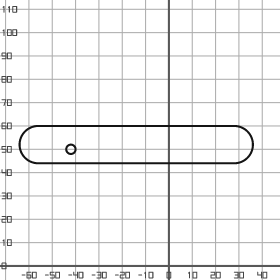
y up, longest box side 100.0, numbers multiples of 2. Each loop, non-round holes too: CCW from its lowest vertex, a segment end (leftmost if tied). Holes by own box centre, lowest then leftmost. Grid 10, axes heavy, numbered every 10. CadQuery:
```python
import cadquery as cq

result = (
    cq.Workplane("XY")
    .moveTo(-56.0, 44.0)
    .lineTo(28.0, 44.0)
    .threePointArc((36.0, 52.0), (28.0, 60.0))
    .lineTo(-56.0, 60.0)
    .threePointArc((-64.0, 52.0), (-56.0, 44.0))
    .close()
    .moveTo(-42.0, 50.0)
    .circle(2.0)
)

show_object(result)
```